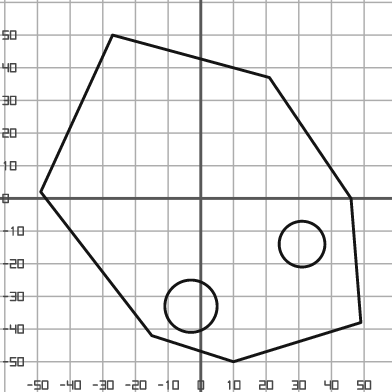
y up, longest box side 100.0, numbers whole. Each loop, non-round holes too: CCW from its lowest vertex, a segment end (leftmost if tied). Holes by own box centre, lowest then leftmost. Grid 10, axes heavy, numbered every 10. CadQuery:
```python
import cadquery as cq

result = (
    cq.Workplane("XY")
    .moveTo(10.0, -50.0)
    .lineTo(49.0, -38.0)
    .lineTo(46.0, 0.0)
    .lineTo(21.0, 37.0)
    .lineTo(-27.0, 50.0)
    .lineTo(-49.0, 2.0)
    .lineTo(-15.0, -42.0)
    .close()
    .moveTo(-3.0, -33.0)
    .circle(8.0)
    .moveTo(31.0, -14.0)
    .circle(7.0)
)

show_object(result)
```